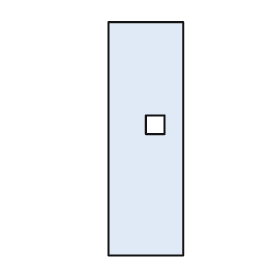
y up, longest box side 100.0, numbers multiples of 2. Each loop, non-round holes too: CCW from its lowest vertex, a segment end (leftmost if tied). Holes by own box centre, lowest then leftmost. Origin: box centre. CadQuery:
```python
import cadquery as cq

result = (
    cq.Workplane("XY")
    .moveTo(-16.0, -50.0)
    .lineTo(16.0, -50.0)
    .lineTo(16.0, 50.0)
    .lineTo(-16.0, 50.0)
    .close()
    .moveTo(0.0, 2.0)
    .lineTo(8.0, 2.0)
    .lineTo(8.0, 10.0)
    .lineTo(0.0, 10.0)
    .close()
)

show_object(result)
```